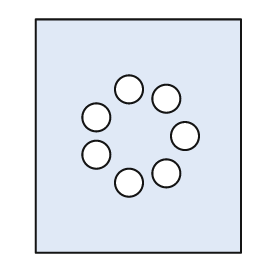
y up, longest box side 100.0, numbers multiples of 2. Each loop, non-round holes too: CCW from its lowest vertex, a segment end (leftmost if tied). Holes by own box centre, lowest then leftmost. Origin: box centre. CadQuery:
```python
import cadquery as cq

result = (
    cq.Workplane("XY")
    .moveTo(-44.0, -50.0)
    .lineTo(44.0, -50.0)
    .lineTo(44.0, 50.0)
    .lineTo(-44.0, 50.0)
    .close()
    .moveTo(-4.0, -20.0)
    .circle(6.0)
    .moveTo(12.0, -16.0)
    .circle(6.0)
    .moveTo(-18.0, -8.0)
    .circle(6.0)
    .moveTo(20.0, 0.0)
    .circle(6.0)
    .moveTo(-18.0, 8.0)
    .circle(6.0)
    .moveTo(12.0, 16.0)
    .circle(6.0)
    .moveTo(-4.0, 20.0)
    .circle(6.0)
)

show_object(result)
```